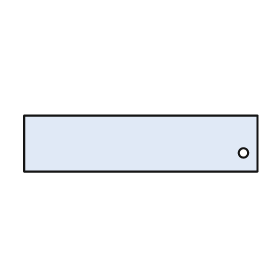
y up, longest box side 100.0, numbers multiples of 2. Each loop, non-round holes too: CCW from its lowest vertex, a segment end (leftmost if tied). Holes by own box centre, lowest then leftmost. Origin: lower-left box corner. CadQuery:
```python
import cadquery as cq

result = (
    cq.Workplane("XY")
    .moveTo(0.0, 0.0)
    .lineTo(100.0, 0.0)
    .lineTo(100.0, 24.0)
    .lineTo(0.0, 24.0)
    .close()
    .moveTo(94.0, 8.0)
    .circle(2.0)
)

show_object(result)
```